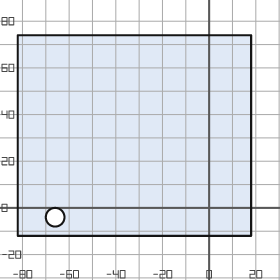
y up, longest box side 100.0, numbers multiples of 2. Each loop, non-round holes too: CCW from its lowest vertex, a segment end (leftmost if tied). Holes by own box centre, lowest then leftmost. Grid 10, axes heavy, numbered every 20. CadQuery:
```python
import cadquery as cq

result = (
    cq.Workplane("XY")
    .moveTo(-82.0, -12.0)
    .lineTo(18.0, -12.0)
    .lineTo(18.0, 74.0)
    .lineTo(-82.0, 74.0)
    .close()
    .moveTo(-66.0, -4.0)
    .circle(4.0)
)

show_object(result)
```